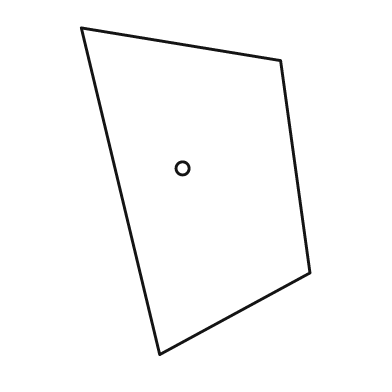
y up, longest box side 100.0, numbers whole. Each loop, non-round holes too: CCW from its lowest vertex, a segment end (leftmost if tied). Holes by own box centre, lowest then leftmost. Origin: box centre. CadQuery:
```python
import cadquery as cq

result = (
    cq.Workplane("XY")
    .moveTo(-11.0, -50.0)
    .lineTo(35.0, -25.0)
    .lineTo(26.0, 40.0)
    .lineTo(-35.0, 50.0)
    .close()
    .moveTo(-4.0, 7.0)
    .circle(2.0)
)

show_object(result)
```